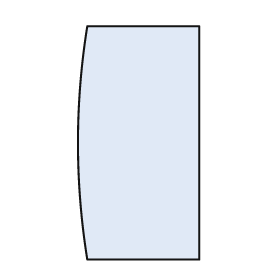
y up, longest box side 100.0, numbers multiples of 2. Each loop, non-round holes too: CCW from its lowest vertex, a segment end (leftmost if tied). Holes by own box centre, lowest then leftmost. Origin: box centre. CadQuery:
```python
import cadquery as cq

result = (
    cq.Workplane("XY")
    .moveTo(-22.0, -50.0)
    .lineTo(26.0, -50.0)
    .lineTo(26.0, 50.0)
    .lineTo(-22.0, 50.0)
    .threePointArc((-26.0, 0.0), (-22.0, -50.0))
    .close()
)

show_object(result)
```